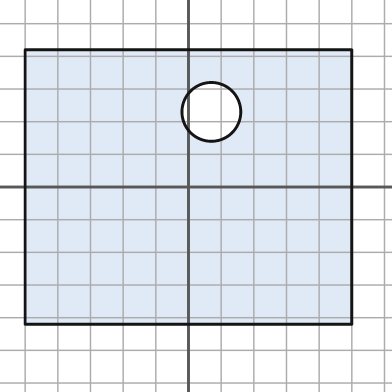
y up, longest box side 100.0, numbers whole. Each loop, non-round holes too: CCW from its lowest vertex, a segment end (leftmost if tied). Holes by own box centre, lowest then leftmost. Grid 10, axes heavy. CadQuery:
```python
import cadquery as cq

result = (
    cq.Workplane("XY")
    .moveTo(-50.0, -42.0)
    .lineTo(50.0, -42.0)
    .lineTo(50.0, 42.0)
    .lineTo(-50.0, 42.0)
    .close()
    .moveTo(7.0, 23.0)
    .circle(9.0)
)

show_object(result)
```